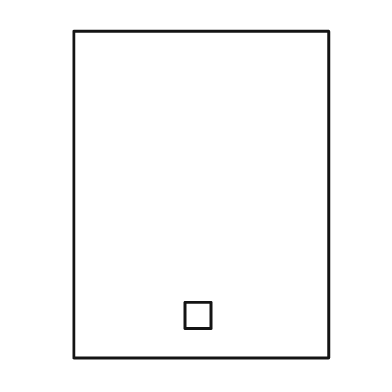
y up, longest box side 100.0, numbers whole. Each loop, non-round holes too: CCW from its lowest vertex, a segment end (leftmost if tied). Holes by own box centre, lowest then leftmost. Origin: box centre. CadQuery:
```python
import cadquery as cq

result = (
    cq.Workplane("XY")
    .moveTo(-39.0, -50.0)
    .lineTo(39.0, -50.0)
    .lineTo(39.0, 50.0)
    .lineTo(-39.0, 50.0)
    .close()
    .moveTo(-5.0, -41.0)
    .lineTo(3.0, -41.0)
    .lineTo(3.0, -33.0)
    .lineTo(-5.0, -33.0)
    .close()
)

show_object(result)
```